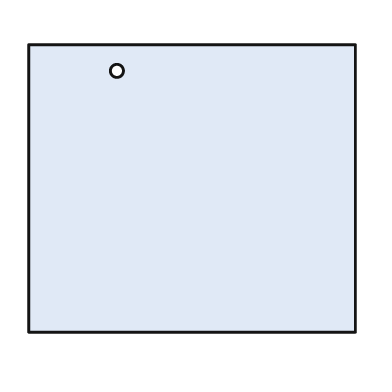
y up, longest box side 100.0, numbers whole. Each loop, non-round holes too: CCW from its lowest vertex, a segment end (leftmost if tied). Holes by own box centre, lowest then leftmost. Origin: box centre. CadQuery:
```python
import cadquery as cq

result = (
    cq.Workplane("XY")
    .moveTo(-50.0, -44.0)
    .lineTo(50.0, -44.0)
    .lineTo(50.0, 44.0)
    .lineTo(-50.0, 44.0)
    .close()
    .moveTo(-23.0, 36.0)
    .circle(2.0)
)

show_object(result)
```